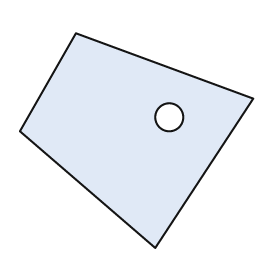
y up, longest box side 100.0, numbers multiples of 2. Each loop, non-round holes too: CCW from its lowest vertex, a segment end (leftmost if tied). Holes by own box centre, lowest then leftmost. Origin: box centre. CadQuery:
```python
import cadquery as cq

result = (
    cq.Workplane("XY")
    .moveTo(8.0, -46.0)
    .lineTo(50.0, 18.0)
    .lineTo(-26.0, 46.0)
    .lineTo(-50.0, 4.0)
    .close()
    .moveTo(14.0, 10.0)
    .circle(6.0)
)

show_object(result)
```